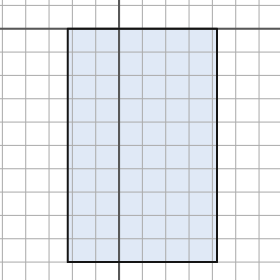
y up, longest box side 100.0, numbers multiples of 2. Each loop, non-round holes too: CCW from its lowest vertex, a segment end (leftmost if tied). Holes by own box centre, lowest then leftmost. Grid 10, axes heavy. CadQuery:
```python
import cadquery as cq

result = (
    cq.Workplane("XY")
    .moveTo(-22.0, -100.0)
    .lineTo(42.0, -100.0)
    .lineTo(42.0, 0.0)
    .lineTo(-22.0, 0.0)
    .close()
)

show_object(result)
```